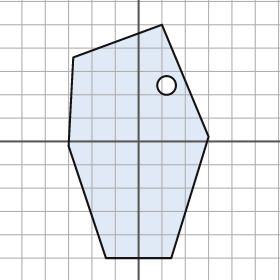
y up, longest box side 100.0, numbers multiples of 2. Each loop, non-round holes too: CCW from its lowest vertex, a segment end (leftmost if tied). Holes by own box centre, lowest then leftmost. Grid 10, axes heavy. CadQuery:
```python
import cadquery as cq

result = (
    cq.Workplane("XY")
    .moveTo(-14.0, -50.0)
    .lineTo(14.0, -50.0)
    .lineTo(30.0, 2.0)
    .lineTo(10.0, 50.0)
    .lineTo(-28.0, 36.0)
    .lineTo(-30.0, -2.0)
    .close()
    .moveTo(12.0, 24.0)
    .circle(4.0)
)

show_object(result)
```